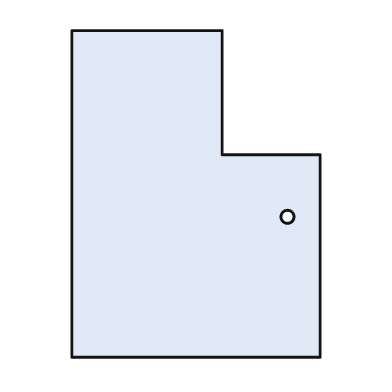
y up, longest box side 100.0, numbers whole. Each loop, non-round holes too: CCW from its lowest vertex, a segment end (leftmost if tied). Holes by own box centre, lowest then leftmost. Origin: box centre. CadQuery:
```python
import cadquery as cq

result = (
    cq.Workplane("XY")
    .moveTo(-38.0, -50.0)
    .lineTo(38.0, -50.0)
    .lineTo(38.0, 12.0)
    .lineTo(8.0, 12.0)
    .lineTo(8.0, 50.0)
    .lineTo(-38.0, 50.0)
    .close()
    .moveTo(28.0, -7.0)
    .circle(2.0)
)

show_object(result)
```